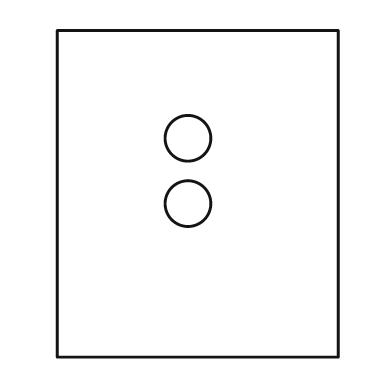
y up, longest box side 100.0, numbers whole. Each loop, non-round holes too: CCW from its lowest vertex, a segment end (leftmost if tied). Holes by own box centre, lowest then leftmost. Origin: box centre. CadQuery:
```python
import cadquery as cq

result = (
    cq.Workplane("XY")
    .moveTo(-43.0, -50.0)
    .lineTo(43.0, -50.0)
    .lineTo(43.0, 50.0)
    .lineTo(-43.0, 50.0)
    .close()
    .moveTo(-3.0, -3.0)
    .circle(7.0)
    .moveTo(-3.0, 17.0)
    .circle(7.0)
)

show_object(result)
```